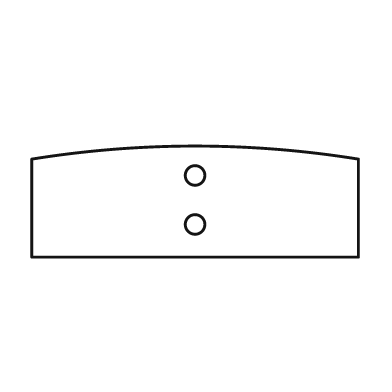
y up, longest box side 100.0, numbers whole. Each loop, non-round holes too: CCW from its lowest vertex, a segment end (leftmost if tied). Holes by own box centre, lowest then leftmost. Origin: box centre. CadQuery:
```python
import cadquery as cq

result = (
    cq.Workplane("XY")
    .moveTo(-50.0, -17.0)
    .lineTo(50.0, -17.0)
    .lineTo(50.0, 13.0)
    .threePointArc((0.0, 17.0), (-50.0, 13.0))
    .close()
    .moveTo(0.0, -7.0)
    .circle(3.0)
    .moveTo(0.0, 8.0)
    .circle(3.0)
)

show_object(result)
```